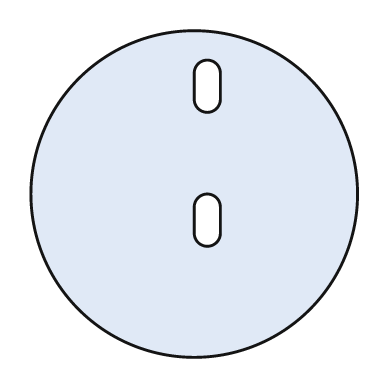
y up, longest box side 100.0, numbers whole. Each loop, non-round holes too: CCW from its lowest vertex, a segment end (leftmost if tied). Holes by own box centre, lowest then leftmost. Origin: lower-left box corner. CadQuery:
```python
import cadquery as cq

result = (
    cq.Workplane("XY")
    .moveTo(50.0, 50.0)
    .circle(50.0)
    .moveTo(50.0, 38.0)
    .threePointArc((54.0, 34.0), (58.0, 38.0))
    .lineTo(58.0, 46.0)
    .threePointArc((54.0, 50.0), (50.0, 46.0))
    .close()
    .moveTo(50.0, 79.0)
    .threePointArc((54.0, 75.0), (58.0, 79.0))
    .lineTo(58.0, 87.0)
    .threePointArc((54.0, 91.0), (50.0, 87.0))
    .close()
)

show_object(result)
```